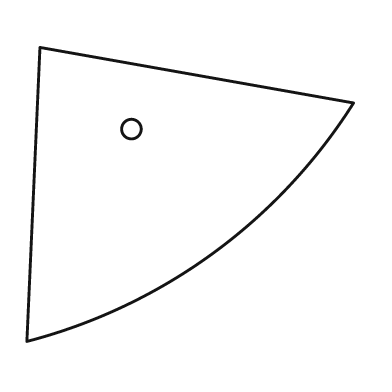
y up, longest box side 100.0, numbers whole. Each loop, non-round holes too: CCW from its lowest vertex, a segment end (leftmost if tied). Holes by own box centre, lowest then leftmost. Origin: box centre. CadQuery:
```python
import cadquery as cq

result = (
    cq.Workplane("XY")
    .moveTo(-50.0, -45.0)
    .threePointArc((7.0, -18.0), (50.0, 28.0))
    .lineTo(-46.0, 45.0)
    .close()
    .moveTo(-18.0, 20.0)
    .circle(3.0)
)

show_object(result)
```